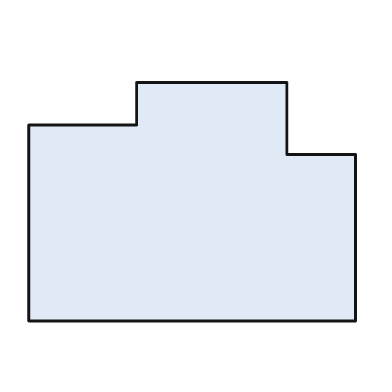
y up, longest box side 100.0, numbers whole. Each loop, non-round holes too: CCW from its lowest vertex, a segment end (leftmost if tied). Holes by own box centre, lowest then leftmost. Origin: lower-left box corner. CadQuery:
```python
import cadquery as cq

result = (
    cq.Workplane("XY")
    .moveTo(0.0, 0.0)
    .lineTo(100.0, 0.0)
    .lineTo(100.0, 51.0)
    .lineTo(79.0, 51.0)
    .lineTo(79.0, 73.0)
    .lineTo(33.0, 73.0)
    .lineTo(33.0, 60.0)
    .lineTo(0.0, 60.0)
    .close()
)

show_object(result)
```